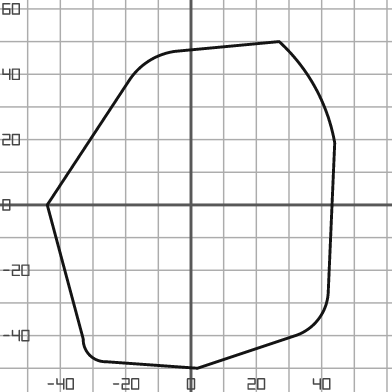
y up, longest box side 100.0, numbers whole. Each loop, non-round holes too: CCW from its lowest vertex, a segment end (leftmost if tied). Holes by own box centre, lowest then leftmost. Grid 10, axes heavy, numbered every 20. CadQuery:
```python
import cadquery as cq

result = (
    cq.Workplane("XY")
    .moveTo(2.0, -50.0)
    .lineTo(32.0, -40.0)
    .threePointArc((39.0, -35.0), (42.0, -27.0))
    .lineTo(44.0, 19.0)
    .threePointArc((38.0, 36.0), (27.0, 50.0))
    .lineTo(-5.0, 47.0)
    .threePointArc((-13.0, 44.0), (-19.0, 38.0))
    .lineTo(-44.0, 0.0)
    .lineTo(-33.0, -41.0)
    .threePointArc((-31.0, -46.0), (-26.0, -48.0))
    .close()
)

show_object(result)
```